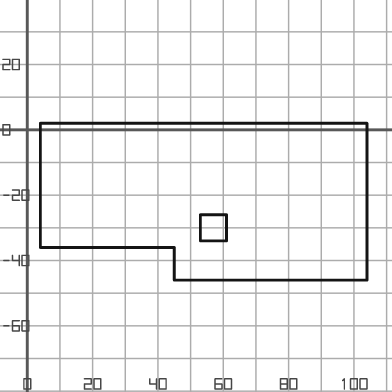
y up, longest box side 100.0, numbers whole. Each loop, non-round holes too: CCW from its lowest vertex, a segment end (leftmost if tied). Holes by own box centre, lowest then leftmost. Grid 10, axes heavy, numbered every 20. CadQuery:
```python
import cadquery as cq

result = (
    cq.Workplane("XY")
    .moveTo(45.0, -46.0)
    .lineTo(104.0, -46.0)
    .lineTo(104.0, 2.0)
    .lineTo(4.0, 2.0)
    .lineTo(4.0, -36.0)
    .lineTo(45.0, -36.0)
    .close()
    .moveTo(53.0, -34.0)
    .lineTo(61.0, -34.0)
    .lineTo(61.0, -26.0)
    .lineTo(53.0, -26.0)
    .close()
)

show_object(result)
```